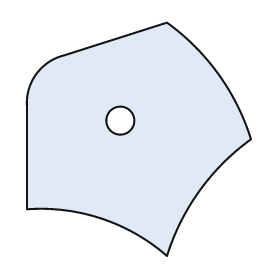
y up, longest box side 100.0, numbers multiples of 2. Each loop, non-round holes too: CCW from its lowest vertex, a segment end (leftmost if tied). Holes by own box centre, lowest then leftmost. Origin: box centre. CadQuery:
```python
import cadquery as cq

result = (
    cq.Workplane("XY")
    .moveTo(12.0, -50.0)
    .threePointArc((26.0, -22.0), (48.0, 0.0))
    .threePointArc((34.0, 28.0), (12.0, 50.0))
    .lineTo(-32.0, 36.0)
    .threePointArc((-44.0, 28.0), (-48.0, 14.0))
    .lineTo(-48.0, -30.0)
    .threePointArc((-16.0, -34.0), (12.0, -50.0))
    .close()
    .moveTo(-8.0, 8.0)
    .circle(6.0)
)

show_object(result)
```